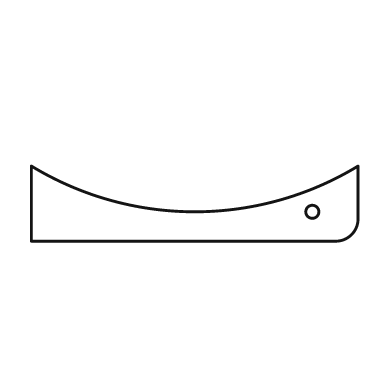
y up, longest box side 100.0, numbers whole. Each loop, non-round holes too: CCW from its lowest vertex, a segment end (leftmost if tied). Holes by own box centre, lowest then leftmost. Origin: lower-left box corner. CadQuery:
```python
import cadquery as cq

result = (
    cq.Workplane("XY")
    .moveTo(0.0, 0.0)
    .lineTo(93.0, 0.0)
    .threePointArc((98.0, 2.0), (100.0, 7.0))
    .lineTo(100.0, 23.0)
    .threePointArc((50.0, 9.0), (0.0, 23.0))
    .close()
    .moveTo(86.0, 9.0)
    .circle(2.0)
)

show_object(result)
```